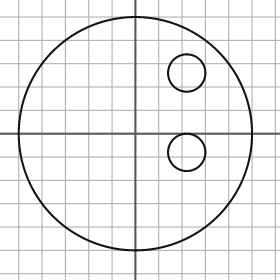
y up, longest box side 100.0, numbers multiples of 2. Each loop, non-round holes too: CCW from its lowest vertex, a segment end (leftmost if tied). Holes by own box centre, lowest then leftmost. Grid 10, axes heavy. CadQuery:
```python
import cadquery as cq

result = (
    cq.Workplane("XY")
    .moveTo(0.0, 0.0)
    .circle(50.0)
    .moveTo(22.0, -8.0)
    .circle(8.0)
    .moveTo(22.0, 26.0)
    .circle(8.0)
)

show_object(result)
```